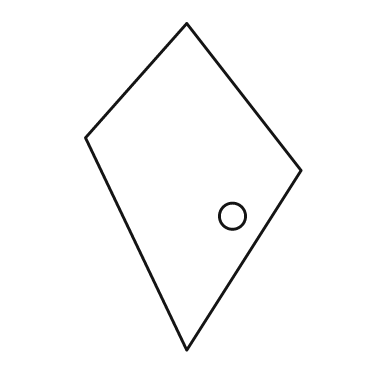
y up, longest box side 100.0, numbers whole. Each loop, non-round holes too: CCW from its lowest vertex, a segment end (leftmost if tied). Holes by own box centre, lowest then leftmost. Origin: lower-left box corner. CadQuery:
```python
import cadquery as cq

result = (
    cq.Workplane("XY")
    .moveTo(31.0, 0.0)
    .lineTo(66.0, 55.0)
    .lineTo(31.0, 100.0)
    .lineTo(0.0, 65.0)
    .close()
    .moveTo(45.0, 41.0)
    .circle(4.0)
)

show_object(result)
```